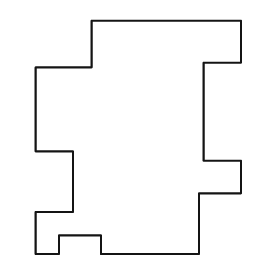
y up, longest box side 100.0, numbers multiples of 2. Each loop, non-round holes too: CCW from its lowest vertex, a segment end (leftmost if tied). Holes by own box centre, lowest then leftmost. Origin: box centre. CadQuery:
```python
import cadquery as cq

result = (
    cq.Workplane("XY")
    .moveTo(-44.0, -50.0)
    .lineTo(-34.0, -50.0)
    .lineTo(-34.0, -42.0)
    .lineTo(-16.0, -42.0)
    .lineTo(-16.0, -50.0)
    .lineTo(26.0, -50.0)
    .lineTo(26.0, -24.0)
    .lineTo(44.0, -24.0)
    .lineTo(44.0, -10.0)
    .lineTo(28.0, -10.0)
    .lineTo(28.0, 32.0)
    .lineTo(44.0, 32.0)
    .lineTo(44.0, 50.0)
    .lineTo(-20.0, 50.0)
    .lineTo(-20.0, 30.0)
    .lineTo(-44.0, 30.0)
    .lineTo(-44.0, -6.0)
    .lineTo(-28.0, -6.0)
    .lineTo(-28.0, -32.0)
    .lineTo(-44.0, -32.0)
    .close()
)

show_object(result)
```